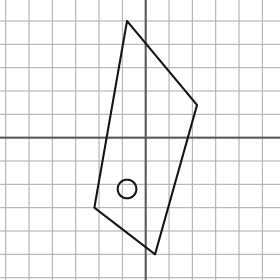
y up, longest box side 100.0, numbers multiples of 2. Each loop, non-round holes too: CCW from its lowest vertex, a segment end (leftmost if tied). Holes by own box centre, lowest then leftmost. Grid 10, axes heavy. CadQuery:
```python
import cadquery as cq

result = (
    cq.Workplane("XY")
    .moveTo(4.0, -50.0)
    .lineTo(22.0, 14.0)
    .lineTo(-8.0, 50.0)
    .lineTo(-22.0, -30.0)
    .close()
    .moveTo(-8.0, -22.0)
    .circle(4.0)
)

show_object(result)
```